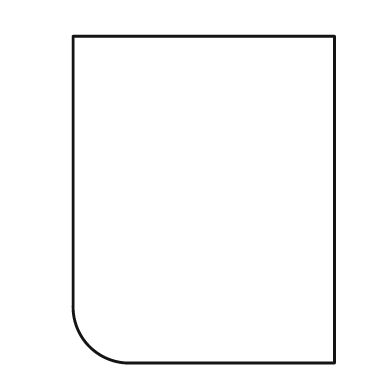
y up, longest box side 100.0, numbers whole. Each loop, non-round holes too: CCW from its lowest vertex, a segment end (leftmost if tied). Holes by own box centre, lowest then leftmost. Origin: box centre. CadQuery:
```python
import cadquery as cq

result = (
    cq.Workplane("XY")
    .moveTo(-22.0, -50.0)
    .lineTo(40.0, -50.0)
    .lineTo(40.0, 50.0)
    .lineTo(-40.0, 50.0)
    .lineTo(-40.0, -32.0)
    .threePointArc((-35.0, -45.0), (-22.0, -50.0))
    .close()
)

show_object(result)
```